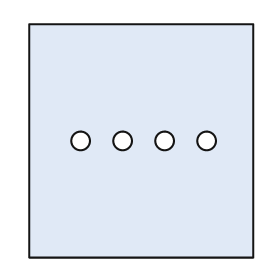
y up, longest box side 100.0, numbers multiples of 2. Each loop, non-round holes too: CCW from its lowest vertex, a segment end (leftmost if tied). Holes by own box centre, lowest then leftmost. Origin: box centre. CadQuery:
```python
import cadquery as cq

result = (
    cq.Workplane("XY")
    .moveTo(-48.0, -50.0)
    .lineTo(48.0, -50.0)
    .lineTo(48.0, 50.0)
    .lineTo(-48.0, 50.0)
    .close()
    .moveTo(-26.0, 0.0)
    .circle(4.0)
    .moveTo(-8.0, 0.0)
    .circle(4.0)
    .moveTo(10.0, 0.0)
    .circle(4.0)
    .moveTo(28.0, 0.0)
    .circle(4.0)
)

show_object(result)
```